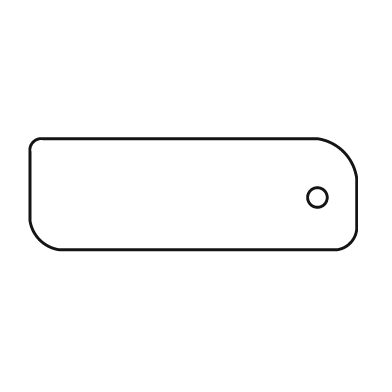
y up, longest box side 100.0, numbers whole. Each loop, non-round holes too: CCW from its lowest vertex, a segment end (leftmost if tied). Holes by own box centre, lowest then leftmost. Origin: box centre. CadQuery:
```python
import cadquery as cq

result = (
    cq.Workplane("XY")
    .moveTo(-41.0, -17.0)
    .lineTo(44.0, -17.0)
    .threePointArc((48.0, -15.0), (50.0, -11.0))
    .lineTo(50.0, 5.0)
    .threePointArc((46.0, 13.0), (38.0, 17.0))
    .lineTo(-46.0, 17.0)
    .threePointArc((-49.0, 16.0), (-50.0, 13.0))
    .lineTo(-50.0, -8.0)
    .threePointArc((-47.0, -14.0), (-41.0, -17.0))
    .close()
    .moveTo(38.0, -1.0)
    .circle(3.0)
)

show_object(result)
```